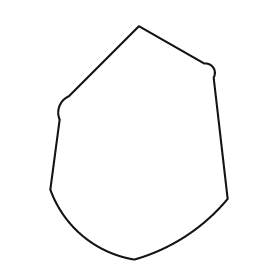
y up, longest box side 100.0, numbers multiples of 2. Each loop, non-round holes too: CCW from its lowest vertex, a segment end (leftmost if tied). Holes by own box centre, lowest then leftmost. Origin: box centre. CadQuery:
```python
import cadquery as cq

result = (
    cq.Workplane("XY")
    .moveTo(-2.0, -50.0)
    .threePointArc((20.0, -40.0), (38.0, -24.0))
    .lineTo(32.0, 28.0)
    .threePointArc((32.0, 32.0), (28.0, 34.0))
    .lineTo(0.0, 50.0)
    .lineTo(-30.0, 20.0)
    .threePointArc((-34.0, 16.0), (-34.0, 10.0))
    .lineTo(-38.0, -20.0)
    .threePointArc((-24.0, -40.0), (-2.0, -50.0))
    .close()
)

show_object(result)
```